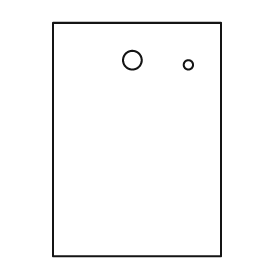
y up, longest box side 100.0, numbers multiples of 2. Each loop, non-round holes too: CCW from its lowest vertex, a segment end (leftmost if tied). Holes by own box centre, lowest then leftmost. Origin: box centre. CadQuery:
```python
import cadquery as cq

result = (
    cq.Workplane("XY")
    .moveTo(-36.0, -50.0)
    .lineTo(36.0, -50.0)
    .lineTo(36.0, 50.0)
    .lineTo(-36.0, 50.0)
    .close()
    .moveTo(22.0, 32.0)
    .circle(2.0)
    .moveTo(-2.0, 34.0)
    .circle(4.0)
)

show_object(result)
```